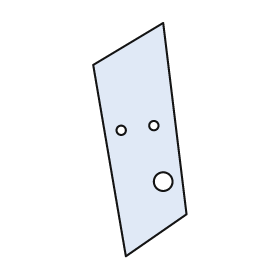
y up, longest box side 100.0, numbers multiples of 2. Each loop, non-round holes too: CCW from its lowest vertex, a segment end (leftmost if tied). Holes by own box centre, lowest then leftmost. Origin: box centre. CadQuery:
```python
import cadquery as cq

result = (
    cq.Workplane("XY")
    .moveTo(-6.0, -50.0)
    .lineTo(20.0, -32.0)
    .lineTo(10.0, 50.0)
    .lineTo(-20.0, 32.0)
    .close()
    .moveTo(10.0, -18.0)
    .circle(4.0)
    .moveTo(-8.0, 4.0)
    .circle(2.0)
    .moveTo(6.0, 6.0)
    .circle(2.0)
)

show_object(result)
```